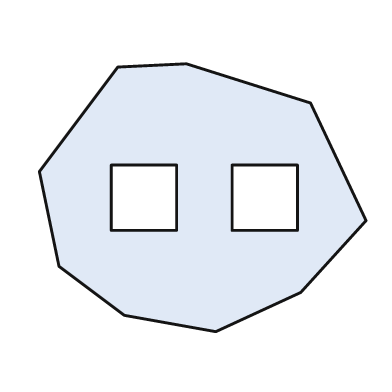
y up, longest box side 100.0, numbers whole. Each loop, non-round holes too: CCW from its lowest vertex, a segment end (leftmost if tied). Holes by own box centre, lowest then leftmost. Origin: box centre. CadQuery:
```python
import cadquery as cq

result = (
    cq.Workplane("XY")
    .moveTo(4.0, -41.0)
    .lineTo(30.0, -29.0)
    .lineTo(50.0, -7.0)
    .lineTo(33.0, 29.0)
    .lineTo(-5.0, 41.0)
    .lineTo(-26.0, 40.0)
    .lineTo(-50.0, 8.0)
    .lineTo(-44.0, -21.0)
    .lineTo(-24.0, -36.0)
    .close()
    .moveTo(-28.0, -10.0)
    .lineTo(-8.0, -10.0)
    .lineTo(-8.0, 10.0)
    .lineTo(-28.0, 10.0)
    .close()
    .moveTo(9.0, -10.0)
    .lineTo(29.0, -10.0)
    .lineTo(29.0, 10.0)
    .lineTo(9.0, 10.0)
    .close()
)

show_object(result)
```